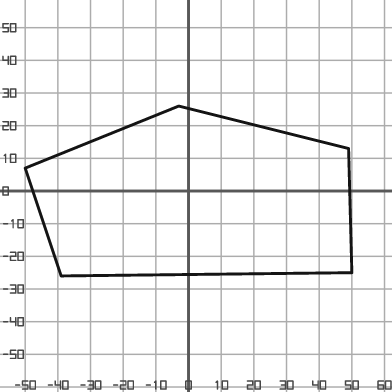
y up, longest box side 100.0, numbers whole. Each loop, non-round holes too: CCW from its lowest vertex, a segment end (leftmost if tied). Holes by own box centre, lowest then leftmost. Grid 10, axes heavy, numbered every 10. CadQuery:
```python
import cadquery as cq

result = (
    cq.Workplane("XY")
    .moveTo(-39.0, -26.0)
    .lineTo(50.0, -25.0)
    .lineTo(49.0, 13.0)
    .lineTo(-3.0, 26.0)
    .lineTo(-50.0, 7.0)
    .close()
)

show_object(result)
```